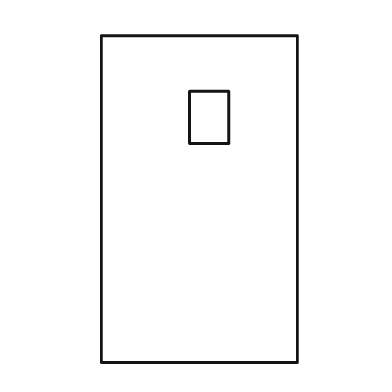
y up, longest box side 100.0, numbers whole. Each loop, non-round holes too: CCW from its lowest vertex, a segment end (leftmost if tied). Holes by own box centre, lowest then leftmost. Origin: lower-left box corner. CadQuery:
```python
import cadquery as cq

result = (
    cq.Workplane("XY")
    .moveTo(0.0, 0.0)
    .lineTo(60.0, 0.0)
    .lineTo(60.0, 100.0)
    .lineTo(0.0, 100.0)
    .close()
    .moveTo(27.0, 67.0)
    .lineTo(39.0, 67.0)
    .lineTo(39.0, 83.0)
    .lineTo(27.0, 83.0)
    .close()
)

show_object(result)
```